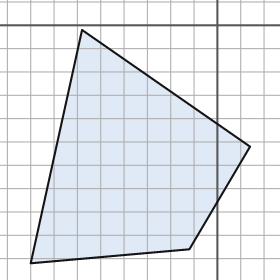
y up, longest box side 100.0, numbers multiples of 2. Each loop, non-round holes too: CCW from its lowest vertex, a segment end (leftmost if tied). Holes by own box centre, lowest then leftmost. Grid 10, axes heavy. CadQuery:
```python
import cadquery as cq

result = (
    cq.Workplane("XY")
    .moveTo(-80.0, -102.0)
    .lineTo(-12.0, -96.0)
    .lineTo(14.0, -52.0)
    .lineTo(-58.0, -2.0)
    .close()
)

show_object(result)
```